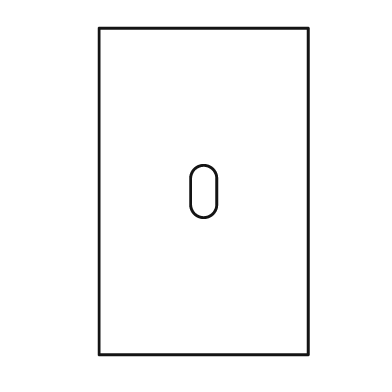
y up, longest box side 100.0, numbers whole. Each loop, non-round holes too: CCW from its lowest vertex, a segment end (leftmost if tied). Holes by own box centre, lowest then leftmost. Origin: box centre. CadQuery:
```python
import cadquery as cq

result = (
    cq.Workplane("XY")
    .moveTo(-32.0, -50.0)
    .lineTo(32.0, -50.0)
    .lineTo(32.0, 50.0)
    .lineTo(-32.0, 50.0)
    .close()
    .moveTo(-4.0, -4.0)
    .threePointArc((0.0, -8.0), (4.0, -4.0))
    .lineTo(4.0, 4.0)
    .threePointArc((0.0, 8.0), (-4.0, 4.0))
    .close()
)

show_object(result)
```